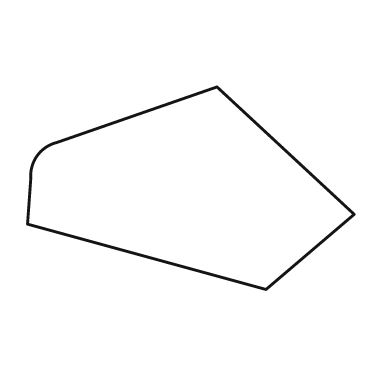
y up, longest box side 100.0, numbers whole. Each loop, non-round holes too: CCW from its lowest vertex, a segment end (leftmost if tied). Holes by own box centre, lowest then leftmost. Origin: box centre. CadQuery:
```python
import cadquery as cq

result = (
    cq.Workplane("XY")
    .moveTo(23.0, -31.0)
    .lineTo(50.0, -8.0)
    .lineTo(8.0, 31.0)
    .lineTo(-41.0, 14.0)
    .threePointArc((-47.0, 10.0), (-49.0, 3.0))
    .lineTo(-50.0, -11.0)
    .close()
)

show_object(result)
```